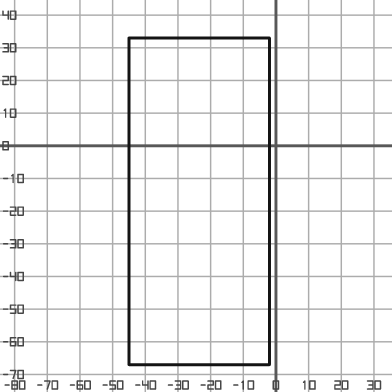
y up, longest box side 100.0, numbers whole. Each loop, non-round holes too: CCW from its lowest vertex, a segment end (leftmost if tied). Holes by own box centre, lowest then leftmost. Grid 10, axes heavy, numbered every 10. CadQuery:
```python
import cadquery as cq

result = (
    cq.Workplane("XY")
    .moveTo(-45.0, -67.0)
    .lineTo(-2.0, -67.0)
    .lineTo(-2.0, 33.0)
    .lineTo(-45.0, 33.0)
    .close()
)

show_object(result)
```